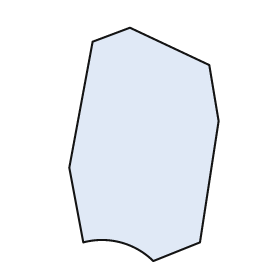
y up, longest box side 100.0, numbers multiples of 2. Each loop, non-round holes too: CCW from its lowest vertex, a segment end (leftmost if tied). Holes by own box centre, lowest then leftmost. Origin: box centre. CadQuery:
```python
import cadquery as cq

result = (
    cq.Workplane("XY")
    .moveTo(4.0, -50.0)
    .lineTo(24.0, -42.0)
    .lineTo(32.0, 10.0)
    .lineTo(28.0, 34.0)
    .lineTo(-6.0, 50.0)
    .lineTo(-22.0, 44.0)
    .lineTo(-32.0, -10.0)
    .lineTo(-26.0, -42.0)
    .threePointArc((-10.0, -42.0), (4.0, -50.0))
    .close()
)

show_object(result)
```